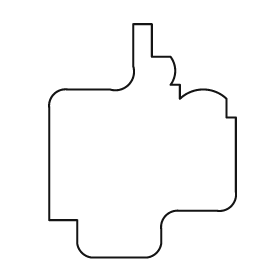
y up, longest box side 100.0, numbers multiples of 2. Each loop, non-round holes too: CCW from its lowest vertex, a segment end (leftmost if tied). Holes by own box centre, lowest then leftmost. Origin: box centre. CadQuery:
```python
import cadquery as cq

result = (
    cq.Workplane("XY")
    .moveTo(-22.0, -50.0)
    .lineTo(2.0, -50.0)
    .threePointArc((6.0, -48.0), (8.0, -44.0))
    .lineTo(8.0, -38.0)
    .threePointArc((10.0, -32.0), (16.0, -30.0))
    .lineTo(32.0, -30.0)
    .threePointArc((38.0, -28.0), (40.0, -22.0))
    .lineTo(40.0, 10.0)
    .lineTo(36.0, 10.0)
    .lineTo(36.0, 18.0)
    .threePointArc((26.0, 22.0), (16.0, 18.0))
    .lineTo(16.0, 24.0)
    .lineTo(12.0, 24.0)
    .threePointArc((14.0, 30.0), (12.0, 36.0))
    .lineTo(4.0, 36.0)
    .lineTo(4.0, 50.0)
    .lineTo(-4.0, 50.0)
    .lineTo(-4.0, 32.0)
    .threePointArc((-6.0, 24.0), (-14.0, 22.0))
    .lineTo(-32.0, 22.0)
    .threePointArc((-38.0, 20.0), (-40.0, 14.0))
    .lineTo(-40.0, -34.0)
    .lineTo(-28.0, -34.0)
    .lineTo(-28.0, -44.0)
    .threePointArc((-26.0, -48.0), (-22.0, -50.0))
    .close()
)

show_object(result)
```